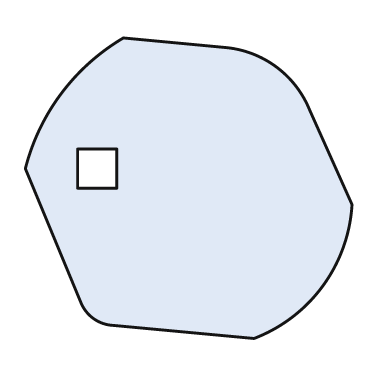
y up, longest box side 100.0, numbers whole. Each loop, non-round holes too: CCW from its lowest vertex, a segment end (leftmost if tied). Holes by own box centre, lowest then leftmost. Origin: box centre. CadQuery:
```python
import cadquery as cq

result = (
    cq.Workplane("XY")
    .moveTo(20.0, -46.0)
    .threePointArc((41.0, -30.0), (50.0, -5.0))
    .lineTo(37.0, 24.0)
    .threePointArc((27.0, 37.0), (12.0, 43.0))
    .lineTo(-20.0, 46.0)
    .threePointArc((-39.0, 29.0), (-50.0, 6.0))
    .lineTo(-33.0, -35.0)
    .threePointArc((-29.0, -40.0), (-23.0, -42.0))
    .close()
    .moveTo(-34.0, 0.0)
    .lineTo(-22.0, 0.0)
    .lineTo(-22.0, 12.0)
    .lineTo(-34.0, 12.0)
    .close()
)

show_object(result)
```